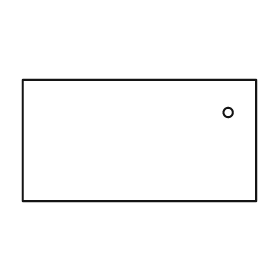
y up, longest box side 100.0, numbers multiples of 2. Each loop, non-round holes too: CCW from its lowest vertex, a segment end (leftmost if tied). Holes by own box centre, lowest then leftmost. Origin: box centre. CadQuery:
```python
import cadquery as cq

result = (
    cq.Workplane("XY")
    .moveTo(-50.0, -26.0)
    .lineTo(50.0, -26.0)
    .lineTo(50.0, 26.0)
    .lineTo(-50.0, 26.0)
    .close()
    .moveTo(38.0, 12.0)
    .circle(2.0)
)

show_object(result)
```